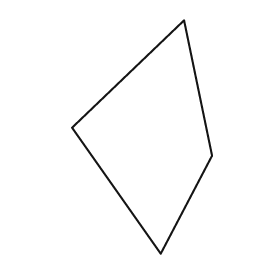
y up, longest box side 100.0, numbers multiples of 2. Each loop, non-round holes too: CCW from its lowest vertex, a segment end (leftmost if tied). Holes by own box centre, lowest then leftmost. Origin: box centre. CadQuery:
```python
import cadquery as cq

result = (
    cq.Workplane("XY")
    .moveTo(8.0, -50.0)
    .lineTo(30.0, -8.0)
    .lineTo(18.0, 50.0)
    .lineTo(-30.0, 4.0)
    .close()
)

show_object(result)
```